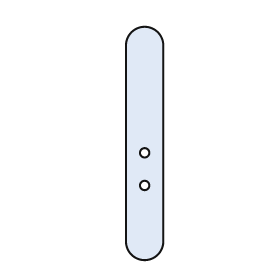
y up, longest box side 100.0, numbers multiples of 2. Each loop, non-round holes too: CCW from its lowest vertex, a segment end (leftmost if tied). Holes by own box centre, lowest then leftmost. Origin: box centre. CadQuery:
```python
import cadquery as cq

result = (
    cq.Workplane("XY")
    .moveTo(-8.0, -42.0)
    .threePointArc((0.0, -50.0), (8.0, -42.0))
    .lineTo(8.0, 42.0)
    .threePointArc((0.0, 50.0), (-8.0, 42.0))
    .close()
    .moveTo(0.0, -18.0)
    .circle(2.0)
    .moveTo(0.0, -4.0)
    .circle(2.0)
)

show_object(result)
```